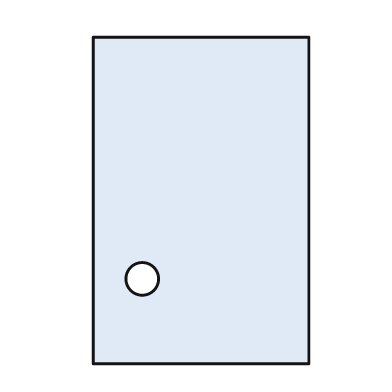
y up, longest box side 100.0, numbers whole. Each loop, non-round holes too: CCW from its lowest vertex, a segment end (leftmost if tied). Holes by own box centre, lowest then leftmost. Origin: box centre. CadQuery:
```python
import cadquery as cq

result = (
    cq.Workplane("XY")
    .moveTo(-33.0, -50.0)
    .lineTo(33.0, -50.0)
    .lineTo(33.0, 50.0)
    .lineTo(-33.0, 50.0)
    .close()
    .moveTo(-18.0, -24.0)
    .circle(5.0)
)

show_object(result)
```